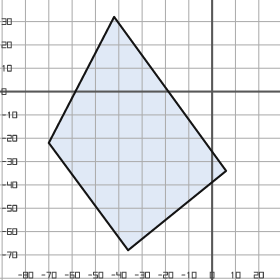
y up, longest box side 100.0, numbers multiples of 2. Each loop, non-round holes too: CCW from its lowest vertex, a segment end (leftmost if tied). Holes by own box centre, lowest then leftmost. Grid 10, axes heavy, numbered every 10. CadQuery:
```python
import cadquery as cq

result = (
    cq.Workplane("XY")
    .moveTo(-36.0, -68.0)
    .lineTo(6.0, -34.0)
    .lineTo(-42.0, 32.0)
    .lineTo(-70.0, -22.0)
    .close()
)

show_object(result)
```